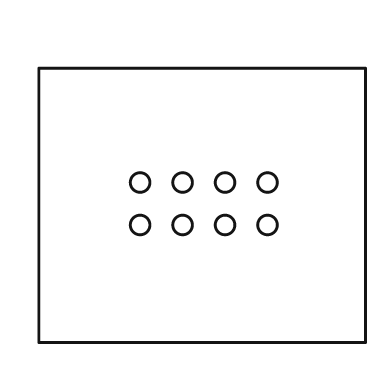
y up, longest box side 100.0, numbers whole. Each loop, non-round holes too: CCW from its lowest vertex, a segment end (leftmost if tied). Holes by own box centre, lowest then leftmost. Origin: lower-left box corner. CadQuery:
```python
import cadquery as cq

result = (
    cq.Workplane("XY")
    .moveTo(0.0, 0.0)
    .lineTo(100.0, 0.0)
    .lineTo(100.0, 84.0)
    .lineTo(0.0, 84.0)
    .close()
    .moveTo(31.0, 36.0)
    .circle(3.0)
    .moveTo(44.0, 36.0)
    .circle(3.0)
    .moveTo(57.0, 36.0)
    .circle(3.0)
    .moveTo(70.0, 36.0)
    .circle(3.0)
    .moveTo(31.0, 49.0)
    .circle(3.0)
    .moveTo(44.0, 49.0)
    .circle(3.0)
    .moveTo(57.0, 49.0)
    .circle(3.0)
    .moveTo(70.0, 49.0)
    .circle(3.0)
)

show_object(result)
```